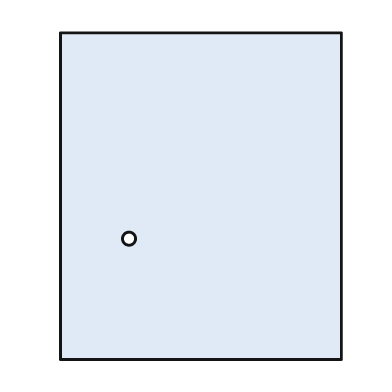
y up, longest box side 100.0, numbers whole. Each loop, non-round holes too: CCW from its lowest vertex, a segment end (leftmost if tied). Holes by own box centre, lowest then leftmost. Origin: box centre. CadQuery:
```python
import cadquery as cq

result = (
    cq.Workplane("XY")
    .moveTo(-43.0, -50.0)
    .lineTo(43.0, -50.0)
    .lineTo(43.0, 50.0)
    .lineTo(-43.0, 50.0)
    .close()
    .moveTo(-22.0, -13.0)
    .circle(2.0)
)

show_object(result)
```